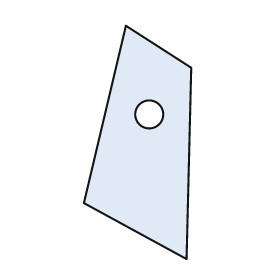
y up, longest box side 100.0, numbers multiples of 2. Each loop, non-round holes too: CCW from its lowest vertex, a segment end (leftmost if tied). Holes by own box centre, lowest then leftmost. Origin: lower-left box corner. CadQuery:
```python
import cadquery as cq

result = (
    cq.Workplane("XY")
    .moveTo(44.0, 0.0)
    .lineTo(46.0, 82.0)
    .lineTo(18.0, 100.0)
    .lineTo(0.0, 24.0)
    .close()
    .moveTo(28.0, 62.0)
    .circle(6.0)
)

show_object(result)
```